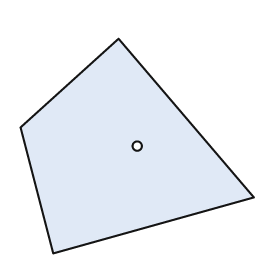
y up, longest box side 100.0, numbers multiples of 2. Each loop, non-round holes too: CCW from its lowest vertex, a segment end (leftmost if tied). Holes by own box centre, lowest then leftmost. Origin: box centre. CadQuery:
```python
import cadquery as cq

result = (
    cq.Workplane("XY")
    .moveTo(-36.0, -46.0)
    .lineTo(50.0, -22.0)
    .lineTo(-8.0, 46.0)
    .lineTo(-50.0, 8.0)
    .close()
    .moveTo(0.0, 0.0)
    .circle(2.0)
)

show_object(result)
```